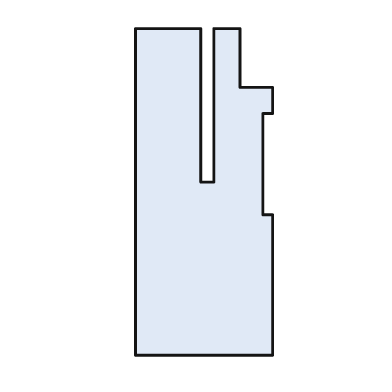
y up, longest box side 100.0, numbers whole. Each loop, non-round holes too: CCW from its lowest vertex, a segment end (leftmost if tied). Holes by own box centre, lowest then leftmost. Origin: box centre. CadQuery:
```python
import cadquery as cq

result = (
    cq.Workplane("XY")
    .moveTo(-21.0, -50.0)
    .lineTo(21.0, -50.0)
    .lineTo(21.0, -7.0)
    .lineTo(18.0, -7.0)
    .lineTo(18.0, 24.0)
    .lineTo(21.0, 24.0)
    .lineTo(21.0, 32.0)
    .lineTo(11.0, 32.0)
    .lineTo(11.0, 50.0)
    .lineTo(3.0, 50.0)
    .lineTo(3.0, 3.0)
    .lineTo(-1.0, 3.0)
    .lineTo(-1.0, 50.0)
    .lineTo(-21.0, 50.0)
    .close()
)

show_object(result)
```